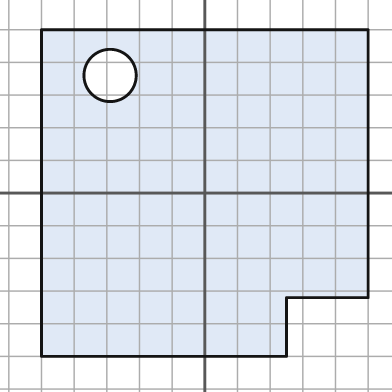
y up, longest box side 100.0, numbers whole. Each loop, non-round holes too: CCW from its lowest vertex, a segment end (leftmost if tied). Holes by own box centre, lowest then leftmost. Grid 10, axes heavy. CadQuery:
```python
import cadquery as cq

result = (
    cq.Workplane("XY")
    .moveTo(-50.0, -50.0)
    .lineTo(25.0, -50.0)
    .lineTo(25.0, -32.0)
    .lineTo(50.0, -32.0)
    .lineTo(50.0, 50.0)
    .lineTo(-50.0, 50.0)
    .close()
    .moveTo(-29.0, 36.0)
    .circle(8.0)
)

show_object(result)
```